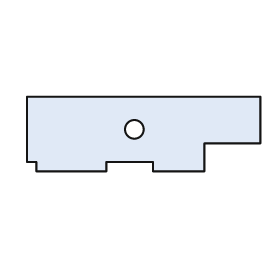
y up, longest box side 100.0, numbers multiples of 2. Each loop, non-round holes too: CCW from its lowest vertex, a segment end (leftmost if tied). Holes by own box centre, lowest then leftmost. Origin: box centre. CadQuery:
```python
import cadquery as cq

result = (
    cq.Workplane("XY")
    .moveTo(-46.0, -16.0)
    .lineTo(-16.0, -16.0)
    .lineTo(-16.0, -12.0)
    .lineTo(4.0, -12.0)
    .lineTo(4.0, -16.0)
    .lineTo(26.0, -16.0)
    .lineTo(26.0, -4.0)
    .lineTo(50.0, -4.0)
    .lineTo(50.0, 16.0)
    .lineTo(-50.0, 16.0)
    .lineTo(-50.0, -12.0)
    .lineTo(-46.0, -12.0)
    .close()
    .moveTo(-4.0, 2.0)
    .circle(4.0)
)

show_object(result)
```